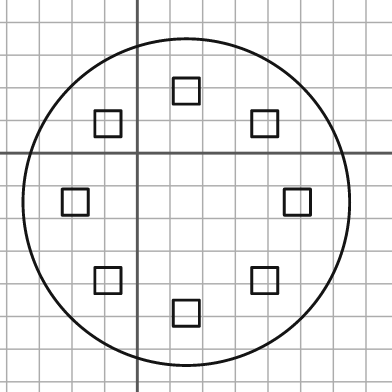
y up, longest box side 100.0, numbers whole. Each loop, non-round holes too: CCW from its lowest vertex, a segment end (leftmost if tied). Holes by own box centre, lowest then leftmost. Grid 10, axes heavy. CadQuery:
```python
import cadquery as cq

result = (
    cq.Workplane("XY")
    .moveTo(15.0, -15.0)
    .circle(50.0)
    .moveTo(11.0, -53.0)
    .lineTo(19.0, -53.0)
    .lineTo(19.0, -45.0)
    .lineTo(11.0, -45.0)
    .close()
    .moveTo(-13.0, -43.0)
    .lineTo(-5.0, -43.0)
    .lineTo(-5.0, -35.0)
    .lineTo(-13.0, -35.0)
    .close()
    .moveTo(35.0, -43.0)
    .lineTo(43.0, -43.0)
    .lineTo(43.0, -35.0)
    .lineTo(35.0, -35.0)
    .close()
    .moveTo(-23.0, -19.0)
    .lineTo(-15.0, -19.0)
    .lineTo(-15.0, -11.0)
    .lineTo(-23.0, -11.0)
    .close()
    .moveTo(45.0, -19.0)
    .lineTo(53.0, -19.0)
    .lineTo(53.0, -11.0)
    .lineTo(45.0, -11.0)
    .close()
    .moveTo(-13.0, 5.0)
    .lineTo(-5.0, 5.0)
    .lineTo(-5.0, 13.0)
    .lineTo(-13.0, 13.0)
    .close()
    .moveTo(35.0, 5.0)
    .lineTo(43.0, 5.0)
    .lineTo(43.0, 13.0)
    .lineTo(35.0, 13.0)
    .close()
    .moveTo(11.0, 15.0)
    .lineTo(19.0, 15.0)
    .lineTo(19.0, 23.0)
    .lineTo(11.0, 23.0)
    .close()
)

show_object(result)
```